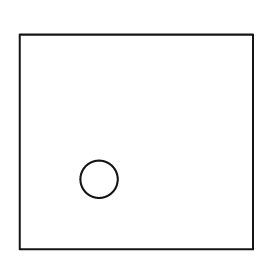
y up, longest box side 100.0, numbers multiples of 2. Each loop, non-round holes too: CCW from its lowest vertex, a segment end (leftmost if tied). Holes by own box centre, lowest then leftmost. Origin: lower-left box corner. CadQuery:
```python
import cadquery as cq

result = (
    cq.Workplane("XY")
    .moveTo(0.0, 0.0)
    .lineTo(100.0, 0.0)
    .lineTo(100.0, 92.0)
    .lineTo(0.0, 92.0)
    .close()
    .moveTo(34.0, 30.0)
    .circle(8.0)
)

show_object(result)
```